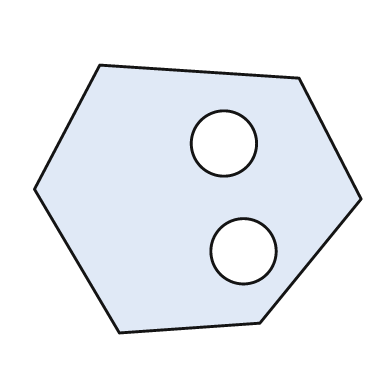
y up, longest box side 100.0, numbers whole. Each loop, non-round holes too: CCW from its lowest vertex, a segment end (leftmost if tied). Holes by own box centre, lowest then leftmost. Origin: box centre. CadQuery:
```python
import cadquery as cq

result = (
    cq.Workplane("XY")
    .moveTo(-24.0, -41.0)
    .lineTo(19.0, -38.0)
    .lineTo(50.0, 0.0)
    .lineTo(31.0, 37.0)
    .lineTo(-30.0, 41.0)
    .lineTo(-50.0, 3.0)
    .close()
    .moveTo(14.0, -16.0)
    .circle(10.0)
    .moveTo(8.0, 17.0)
    .circle(10.0)
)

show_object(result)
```